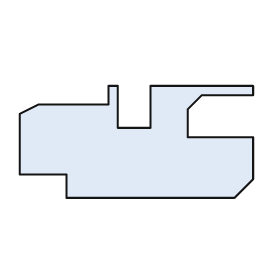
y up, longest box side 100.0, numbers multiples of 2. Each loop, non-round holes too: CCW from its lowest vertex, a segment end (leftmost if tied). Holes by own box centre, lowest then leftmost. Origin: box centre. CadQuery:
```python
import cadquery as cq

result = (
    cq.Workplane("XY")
    .moveTo(-30.0, -24.0)
    .lineTo(42.0, -24.0)
    .lineTo(50.0, -16.0)
    .lineTo(50.0, 2.0)
    .lineTo(22.0, 2.0)
    .lineTo(22.0, 14.0)
    .lineTo(28.0, 20.0)
    .lineTo(50.0, 20.0)
    .lineTo(50.0, 24.0)
    .lineTo(6.0, 24.0)
    .lineTo(6.0, 6.0)
    .lineTo(-8.0, 6.0)
    .lineTo(-8.0, 24.0)
    .lineTo(-12.0, 24.0)
    .lineTo(-12.0, 16.0)
    .lineTo(-42.0, 16.0)
    .lineTo(-50.0, 12.0)
    .lineTo(-50.0, -14.0)
    .lineTo(-30.0, -14.0)
    .close()
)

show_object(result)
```